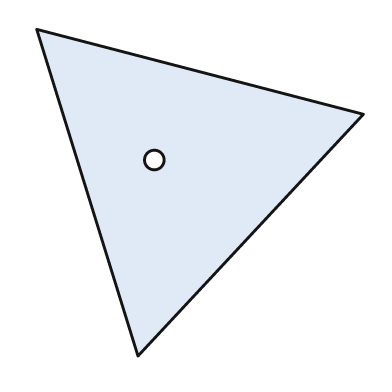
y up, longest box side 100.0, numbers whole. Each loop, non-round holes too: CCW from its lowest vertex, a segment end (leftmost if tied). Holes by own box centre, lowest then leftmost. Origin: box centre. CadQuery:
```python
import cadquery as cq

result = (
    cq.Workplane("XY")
    .moveTo(-19.0, -50.0)
    .lineTo(50.0, 24.0)
    .lineTo(-50.0, 50.0)
    .close()
    .moveTo(-14.0, 10.0)
    .circle(3.0)
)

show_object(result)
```